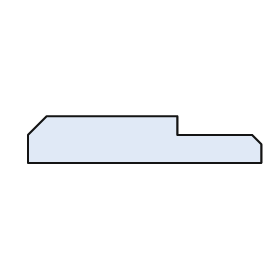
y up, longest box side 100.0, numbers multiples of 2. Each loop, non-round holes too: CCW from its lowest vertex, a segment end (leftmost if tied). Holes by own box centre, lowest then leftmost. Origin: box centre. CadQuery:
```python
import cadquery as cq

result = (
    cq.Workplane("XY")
    .moveTo(-50.0, -10.0)
    .lineTo(50.0, -10.0)
    .lineTo(50.0, -2.0)
    .lineTo(46.0, 2.0)
    .lineTo(14.0, 2.0)
    .lineTo(14.0, 10.0)
    .lineTo(-42.0, 10.0)
    .lineTo(-50.0, 2.0)
    .close()
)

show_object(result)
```